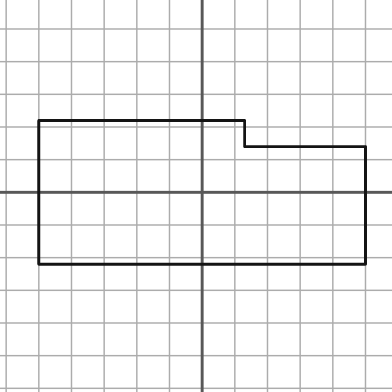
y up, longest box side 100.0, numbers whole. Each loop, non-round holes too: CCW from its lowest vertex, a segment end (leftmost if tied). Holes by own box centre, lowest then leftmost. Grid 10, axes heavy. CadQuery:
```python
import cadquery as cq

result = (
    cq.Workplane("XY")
    .moveTo(-50.0, -22.0)
    .lineTo(50.0, -22.0)
    .lineTo(50.0, 14.0)
    .lineTo(13.0, 14.0)
    .lineTo(13.0, 22.0)
    .lineTo(-50.0, 22.0)
    .close()
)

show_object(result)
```